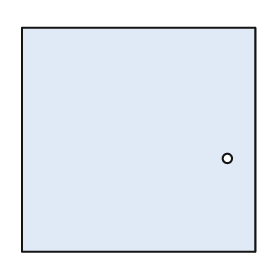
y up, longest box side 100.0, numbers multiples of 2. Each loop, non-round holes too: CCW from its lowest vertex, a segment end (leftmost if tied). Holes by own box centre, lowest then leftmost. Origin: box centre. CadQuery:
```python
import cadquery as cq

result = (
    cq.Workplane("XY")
    .moveTo(-50.0, -48.0)
    .lineTo(50.0, -48.0)
    .lineTo(50.0, 48.0)
    .lineTo(-50.0, 48.0)
    .close()
    .moveTo(38.0, -8.0)
    .circle(2.0)
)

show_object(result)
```